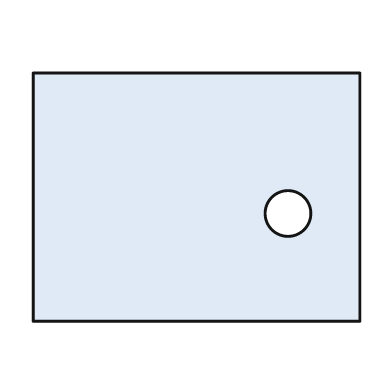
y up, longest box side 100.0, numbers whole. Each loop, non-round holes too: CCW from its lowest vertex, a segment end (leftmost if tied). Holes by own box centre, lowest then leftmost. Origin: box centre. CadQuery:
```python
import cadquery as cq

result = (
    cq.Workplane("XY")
    .moveTo(-50.0, -38.0)
    .lineTo(50.0, -38.0)
    .lineTo(50.0, 38.0)
    .lineTo(-50.0, 38.0)
    .close()
    .moveTo(28.0, -5.0)
    .circle(7.0)
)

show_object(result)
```